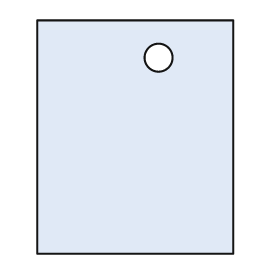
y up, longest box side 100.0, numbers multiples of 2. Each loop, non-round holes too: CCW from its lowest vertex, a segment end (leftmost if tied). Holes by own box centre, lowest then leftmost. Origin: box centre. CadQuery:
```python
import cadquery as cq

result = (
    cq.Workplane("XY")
    .moveTo(-42.0, -50.0)
    .lineTo(42.0, -50.0)
    .lineTo(42.0, 50.0)
    .lineTo(-42.0, 50.0)
    .close()
    .moveTo(10.0, 34.0)
    .circle(6.0)
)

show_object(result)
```